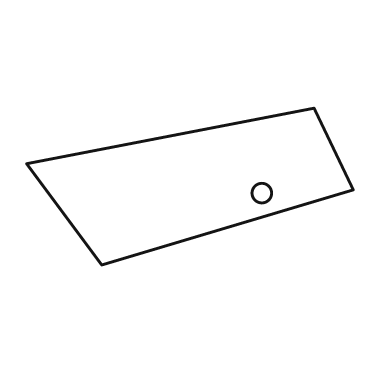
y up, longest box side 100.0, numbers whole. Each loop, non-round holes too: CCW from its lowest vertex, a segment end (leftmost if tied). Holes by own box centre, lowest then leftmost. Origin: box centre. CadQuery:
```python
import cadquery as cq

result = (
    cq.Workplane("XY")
    .moveTo(-27.0, -24.0)
    .lineTo(50.0, -1.0)
    .lineTo(38.0, 24.0)
    .lineTo(-50.0, 7.0)
    .close()
    .moveTo(22.0, -2.0)
    .circle(3.0)
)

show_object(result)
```